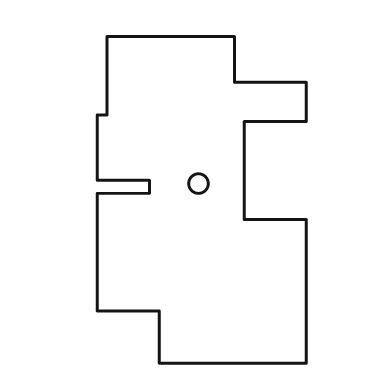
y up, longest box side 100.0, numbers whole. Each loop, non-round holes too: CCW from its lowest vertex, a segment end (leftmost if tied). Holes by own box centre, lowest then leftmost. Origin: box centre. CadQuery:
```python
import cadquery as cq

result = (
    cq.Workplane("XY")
    .moveTo(-13.0, -50.0)
    .lineTo(32.0, -50.0)
    .lineTo(32.0, -6.0)
    .lineTo(13.0, -6.0)
    .lineTo(13.0, 24.0)
    .lineTo(32.0, 24.0)
    .lineTo(32.0, 36.0)
    .lineTo(10.0, 36.0)
    .lineTo(10.0, 50.0)
    .lineTo(-29.0, 50.0)
    .lineTo(-29.0, 26.0)
    .lineTo(-32.0, 26.0)
    .lineTo(-32.0, 6.0)
    .lineTo(-16.0, 6.0)
    .lineTo(-16.0, 2.0)
    .lineTo(-32.0, 2.0)
    .lineTo(-32.0, -34.0)
    .lineTo(-13.0, -34.0)
    .close()
    .moveTo(-1.0, 5.0)
    .circle(3.0)
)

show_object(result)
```